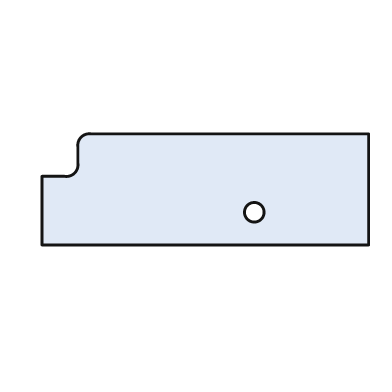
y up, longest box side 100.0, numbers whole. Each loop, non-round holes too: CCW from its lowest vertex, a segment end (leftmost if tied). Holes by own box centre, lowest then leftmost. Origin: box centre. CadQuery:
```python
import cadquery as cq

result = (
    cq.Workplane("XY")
    .moveTo(-50.0, -17.0)
    .lineTo(50.0, -17.0)
    .lineTo(50.0, 17.0)
    .lineTo(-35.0, 17.0)
    .threePointArc((-38.0, 16.0), (-39.0, 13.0))
    .lineTo(-39.0, 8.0)
    .threePointArc((-40.0, 5.0), (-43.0, 4.0))
    .lineTo(-50.0, 4.0)
    .close()
    .moveTo(15.0, -7.0)
    .circle(3.0)
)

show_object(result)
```